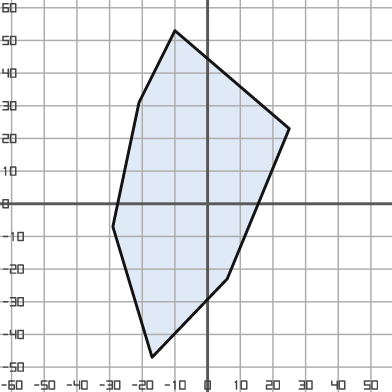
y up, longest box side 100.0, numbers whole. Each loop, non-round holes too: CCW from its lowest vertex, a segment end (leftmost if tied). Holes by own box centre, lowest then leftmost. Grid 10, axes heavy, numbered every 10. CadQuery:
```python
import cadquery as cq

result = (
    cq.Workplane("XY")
    .moveTo(-17.0, -47.0)
    .lineTo(6.0, -23.0)
    .lineTo(25.0, 23.0)
    .lineTo(-10.0, 53.0)
    .lineTo(-21.0, 31.0)
    .lineTo(-29.0, -7.0)
    .close()
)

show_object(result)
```